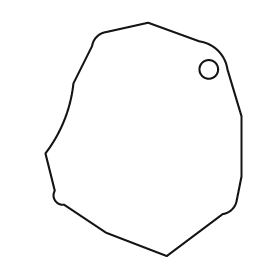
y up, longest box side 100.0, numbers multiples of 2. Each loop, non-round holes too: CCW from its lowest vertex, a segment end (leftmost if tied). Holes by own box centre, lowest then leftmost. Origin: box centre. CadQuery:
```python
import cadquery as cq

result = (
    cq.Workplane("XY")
    .moveTo(10.0, -50.0)
    .lineTo(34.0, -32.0)
    .threePointArc((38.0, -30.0), (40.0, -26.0))
    .lineTo(42.0, -16.0)
    .lineTo(42.0, 10.0)
    .lineTo(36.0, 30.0)
    .threePointArc((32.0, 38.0), (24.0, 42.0))
    .lineTo(2.0, 50.0)
    .lineTo(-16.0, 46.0)
    .threePointArc((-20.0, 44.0), (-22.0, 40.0))
    .lineTo(-30.0, 24.0)
    .threePointArc((-34.0, 8.0), (-42.0, -6.0))
    .lineTo(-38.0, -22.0)
    .threePointArc((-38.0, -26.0), (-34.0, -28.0))
    .lineTo(-16.0, -40.0)
    .close()
    .moveTo(28.0, 30.0)
    .circle(4.0)
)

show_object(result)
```